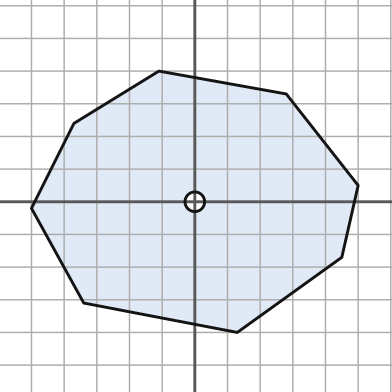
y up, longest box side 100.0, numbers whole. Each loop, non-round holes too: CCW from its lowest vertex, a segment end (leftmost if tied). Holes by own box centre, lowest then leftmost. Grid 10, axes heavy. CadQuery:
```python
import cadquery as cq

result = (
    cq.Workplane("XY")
    .moveTo(13.0, -40.0)
    .lineTo(45.0, -17.0)
    .lineTo(50.0, 5.0)
    .lineTo(28.0, 33.0)
    .lineTo(-11.0, 40.0)
    .lineTo(-37.0, 24.0)
    .lineTo(-50.0, -2.0)
    .lineTo(-34.0, -31.0)
    .close()
    .moveTo(0.0, 0.0)
    .circle(3.0)
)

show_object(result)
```